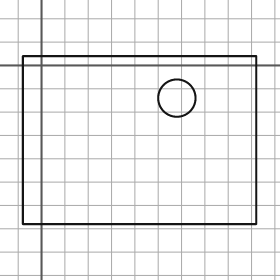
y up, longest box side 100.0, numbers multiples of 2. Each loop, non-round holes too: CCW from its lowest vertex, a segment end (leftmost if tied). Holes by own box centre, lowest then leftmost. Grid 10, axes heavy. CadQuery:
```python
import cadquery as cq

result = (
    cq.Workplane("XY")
    .moveTo(-8.0, -68.0)
    .lineTo(92.0, -68.0)
    .lineTo(92.0, 4.0)
    .lineTo(-8.0, 4.0)
    .close()
    .moveTo(58.0, -14.0)
    .circle(8.0)
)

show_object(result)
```